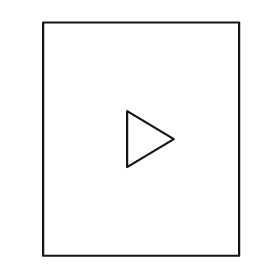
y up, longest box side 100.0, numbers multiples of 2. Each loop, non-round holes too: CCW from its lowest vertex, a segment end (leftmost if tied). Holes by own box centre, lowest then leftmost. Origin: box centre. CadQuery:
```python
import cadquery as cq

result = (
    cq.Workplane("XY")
    .moveTo(-42.0, -50.0)
    .lineTo(42.0, -50.0)
    .lineTo(42.0, 50.0)
    .lineTo(-42.0, 50.0)
    .close()
    .moveTo(-6.0, -12.0)
    .lineTo(14.0, 0.0)
    .lineTo(-6.0, 12.0)
    .close()
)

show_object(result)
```